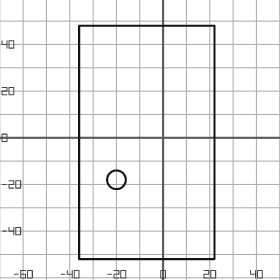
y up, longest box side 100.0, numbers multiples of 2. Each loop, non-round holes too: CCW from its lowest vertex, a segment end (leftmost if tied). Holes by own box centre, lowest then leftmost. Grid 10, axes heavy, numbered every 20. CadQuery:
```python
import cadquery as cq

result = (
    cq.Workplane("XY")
    .moveTo(-36.0, -52.0)
    .lineTo(22.0, -52.0)
    .lineTo(22.0, 48.0)
    .lineTo(-36.0, 48.0)
    .close()
    .moveTo(-20.0, -18.0)
    .circle(4.0)
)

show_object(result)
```